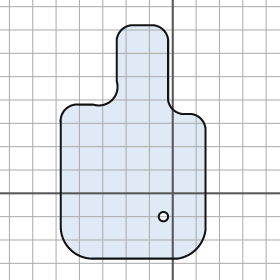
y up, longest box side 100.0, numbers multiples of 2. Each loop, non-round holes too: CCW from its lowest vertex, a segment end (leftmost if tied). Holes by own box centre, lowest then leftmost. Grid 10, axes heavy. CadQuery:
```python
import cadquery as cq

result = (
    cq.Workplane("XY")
    .moveTo(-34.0, -28.0)
    .lineTo(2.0, -28.0)
    .threePointArc((10.0, -24.0), (14.0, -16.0))
    .lineTo(14.0, 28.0)
    .threePointArc((12.0, 32.0), (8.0, 34.0))
    .lineTo(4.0, 34.0)
    .threePointArc((0.0, 36.0), (-2.0, 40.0))
    .lineTo(-2.0, 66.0)
    .threePointArc((-4.0, 70.0), (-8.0, 72.0))
    .lineTo(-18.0, 72.0)
    .threePointArc((-22.0, 70.0), (-24.0, 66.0))
    .lineTo(-24.0, 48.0)
    .threePointArc((-26.0, 40.0), (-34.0, 38.0))
    .lineTo(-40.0, 38.0)
    .threePointArc((-46.0, 36.0), (-48.0, 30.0))
    .lineTo(-48.0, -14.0)
    .threePointArc((-44.0, -24.0), (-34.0, -28.0))
    .close()
    .moveTo(-4.0, -10.0)
    .circle(2.0)
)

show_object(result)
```